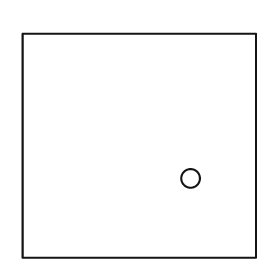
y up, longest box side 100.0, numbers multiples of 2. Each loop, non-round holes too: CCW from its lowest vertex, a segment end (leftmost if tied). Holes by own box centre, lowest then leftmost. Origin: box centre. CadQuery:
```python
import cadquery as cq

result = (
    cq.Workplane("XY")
    .moveTo(-50.0, -48.0)
    .lineTo(50.0, -48.0)
    .lineTo(50.0, 48.0)
    .lineTo(-50.0, 48.0)
    .close()
    .moveTo(22.0, -14.0)
    .circle(4.0)
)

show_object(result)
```